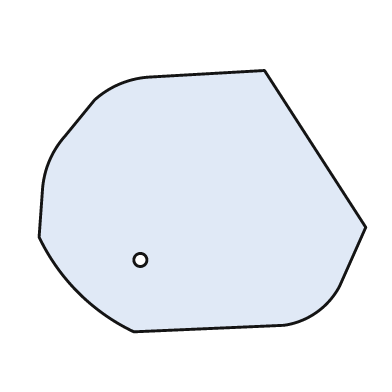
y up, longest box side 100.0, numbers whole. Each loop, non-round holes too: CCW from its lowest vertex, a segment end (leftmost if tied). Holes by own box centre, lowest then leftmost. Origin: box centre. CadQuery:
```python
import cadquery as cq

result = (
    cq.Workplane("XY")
    .moveTo(-21.0, -40.0)
    .lineTo(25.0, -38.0)
    .threePointArc((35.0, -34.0), (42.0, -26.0))
    .lineTo(50.0, -8.0)
    .lineTo(19.0, 40.0)
    .lineTo(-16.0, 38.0)
    .threePointArc((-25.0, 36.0), (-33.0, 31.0))
    .lineTo(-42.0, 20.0)
    .threePointArc((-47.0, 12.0), (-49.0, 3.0))
    .lineTo(-50.0, -11.0)
    .threePointArc((-38.0, -28.0), (-21.0, -40.0))
    .close()
    .moveTo(-19.0, -18.0)
    .circle(2.0)
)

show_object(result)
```